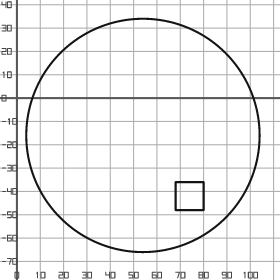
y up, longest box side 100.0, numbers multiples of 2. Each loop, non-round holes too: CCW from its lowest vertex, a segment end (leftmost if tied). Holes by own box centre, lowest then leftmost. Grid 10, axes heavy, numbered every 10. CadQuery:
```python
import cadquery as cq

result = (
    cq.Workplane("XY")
    .moveTo(54.0, -16.0)
    .circle(50.0)
    .moveTo(68.0, -48.0)
    .lineTo(80.0, -48.0)
    .lineTo(80.0, -36.0)
    .lineTo(68.0, -36.0)
    .close()
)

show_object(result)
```